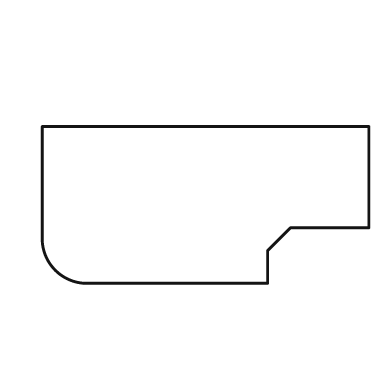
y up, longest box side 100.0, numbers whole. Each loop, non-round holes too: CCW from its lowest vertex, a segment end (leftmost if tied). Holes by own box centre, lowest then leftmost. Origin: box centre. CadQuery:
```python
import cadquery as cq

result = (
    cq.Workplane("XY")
    .moveTo(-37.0, -24.0)
    .lineTo(19.0, -24.0)
    .lineTo(19.0, -14.0)
    .lineTo(26.0, -7.0)
    .lineTo(50.0, -7.0)
    .lineTo(50.0, 24.0)
    .lineTo(-50.0, 24.0)
    .lineTo(-50.0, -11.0)
    .threePointArc((-46.0, -20.0), (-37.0, -24.0))
    .close()
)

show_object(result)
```